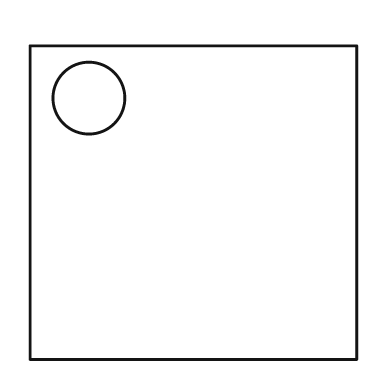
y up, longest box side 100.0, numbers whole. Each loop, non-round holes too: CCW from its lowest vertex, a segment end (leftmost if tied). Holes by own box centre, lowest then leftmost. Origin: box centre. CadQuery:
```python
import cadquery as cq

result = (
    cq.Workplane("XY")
    .moveTo(-50.0, -48.0)
    .lineTo(50.0, -48.0)
    .lineTo(50.0, 48.0)
    .lineTo(-50.0, 48.0)
    .close()
    .moveTo(-32.0, 32.0)
    .circle(11.0)
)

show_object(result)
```